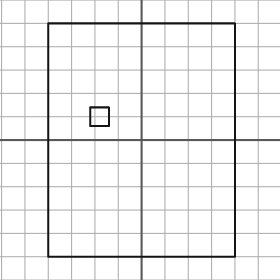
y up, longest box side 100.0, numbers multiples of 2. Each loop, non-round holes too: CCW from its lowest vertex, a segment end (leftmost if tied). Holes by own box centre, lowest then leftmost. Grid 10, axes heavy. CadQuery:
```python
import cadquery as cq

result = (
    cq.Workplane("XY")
    .moveTo(-40.0, -50.0)
    .lineTo(40.0, -50.0)
    .lineTo(40.0, 50.0)
    .lineTo(-40.0, 50.0)
    .close()
    .moveTo(-22.0, 6.0)
    .lineTo(-14.0, 6.0)
    .lineTo(-14.0, 14.0)
    .lineTo(-22.0, 14.0)
    .close()
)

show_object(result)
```